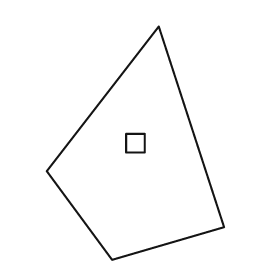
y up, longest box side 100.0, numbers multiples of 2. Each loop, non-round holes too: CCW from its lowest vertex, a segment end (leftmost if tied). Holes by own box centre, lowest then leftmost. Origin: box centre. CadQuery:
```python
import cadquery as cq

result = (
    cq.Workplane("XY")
    .moveTo(-10.0, -50.0)
    .lineTo(38.0, -36.0)
    .lineTo(10.0, 50.0)
    .lineTo(-38.0, -12.0)
    .close()
    .moveTo(-4.0, -4.0)
    .lineTo(4.0, -4.0)
    .lineTo(4.0, 4.0)
    .lineTo(-4.0, 4.0)
    .close()
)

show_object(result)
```